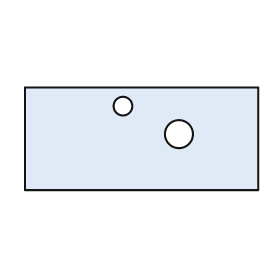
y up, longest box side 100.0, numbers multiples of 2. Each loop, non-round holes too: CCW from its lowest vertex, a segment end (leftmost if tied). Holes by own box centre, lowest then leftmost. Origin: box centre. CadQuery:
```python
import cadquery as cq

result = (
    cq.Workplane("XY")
    .moveTo(-50.0, -22.0)
    .lineTo(50.0, -22.0)
    .lineTo(50.0, 22.0)
    .lineTo(-50.0, 22.0)
    .close()
    .moveTo(16.0, 2.0)
    .circle(6.0)
    .moveTo(-8.0, 14.0)
    .circle(4.0)
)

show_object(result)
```